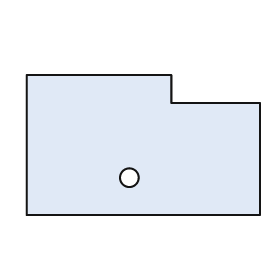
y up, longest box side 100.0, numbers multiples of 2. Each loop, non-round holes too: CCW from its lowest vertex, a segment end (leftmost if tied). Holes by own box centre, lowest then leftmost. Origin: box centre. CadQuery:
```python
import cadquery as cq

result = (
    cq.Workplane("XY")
    .moveTo(-50.0, -30.0)
    .lineTo(50.0, -30.0)
    .lineTo(50.0, 18.0)
    .lineTo(12.0, 18.0)
    .lineTo(12.0, 30.0)
    .lineTo(-50.0, 30.0)
    .close()
    .moveTo(-6.0, -14.0)
    .circle(4.0)
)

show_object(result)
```